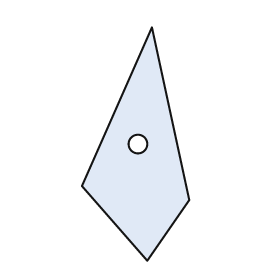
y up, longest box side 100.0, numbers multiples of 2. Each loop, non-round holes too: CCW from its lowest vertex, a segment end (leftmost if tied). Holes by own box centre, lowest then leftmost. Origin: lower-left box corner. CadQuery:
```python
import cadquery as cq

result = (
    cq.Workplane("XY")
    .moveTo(28.0, 0.0)
    .lineTo(46.0, 26.0)
    .lineTo(30.0, 100.0)
    .lineTo(0.0, 32.0)
    .close()
    .moveTo(24.0, 50.0)
    .circle(4.0)
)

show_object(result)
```